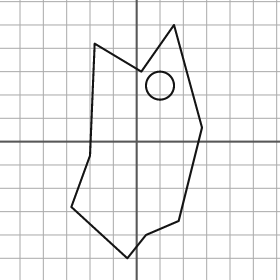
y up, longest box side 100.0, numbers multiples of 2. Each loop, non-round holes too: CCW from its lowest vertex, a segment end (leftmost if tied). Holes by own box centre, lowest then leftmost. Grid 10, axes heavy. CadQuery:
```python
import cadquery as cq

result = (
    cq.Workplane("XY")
    .moveTo(-4.0, -50.0)
    .lineTo(4.0, -40.0)
    .lineTo(18.0, -34.0)
    .lineTo(28.0, 6.0)
    .lineTo(16.0, 50.0)
    .lineTo(2.0, 30.0)
    .lineTo(-18.0, 42.0)
    .lineTo(-20.0, -6.0)
    .lineTo(-28.0, -28.0)
    .close()
    .moveTo(10.0, 24.0)
    .circle(6.0)
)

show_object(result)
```